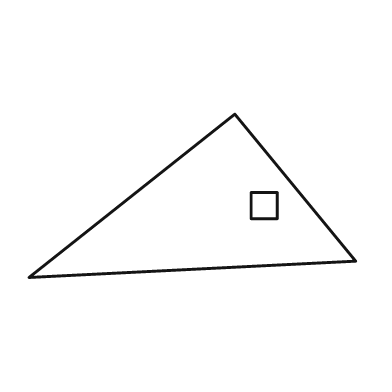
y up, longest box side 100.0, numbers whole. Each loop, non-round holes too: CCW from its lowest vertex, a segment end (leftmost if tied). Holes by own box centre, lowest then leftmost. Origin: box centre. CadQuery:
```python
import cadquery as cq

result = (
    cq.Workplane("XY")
    .moveTo(-50.0, -25.0)
    .lineTo(50.0, -20.0)
    .lineTo(13.0, 25.0)
    .close()
    .moveTo(18.0, -7.0)
    .lineTo(26.0, -7.0)
    .lineTo(26.0, 1.0)
    .lineTo(18.0, 1.0)
    .close()
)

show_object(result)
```